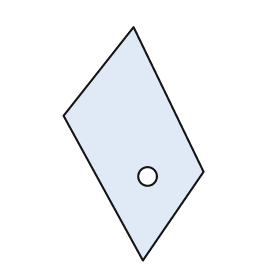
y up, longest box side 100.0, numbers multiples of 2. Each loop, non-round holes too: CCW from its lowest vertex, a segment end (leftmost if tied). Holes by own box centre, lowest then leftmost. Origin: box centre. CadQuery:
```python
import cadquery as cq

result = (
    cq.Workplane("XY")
    .moveTo(4.0, -50.0)
    .lineTo(30.0, -12.0)
    .lineTo(0.0, 50.0)
    .lineTo(-30.0, 12.0)
    .close()
    .moveTo(6.0, -14.0)
    .circle(4.0)
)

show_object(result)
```